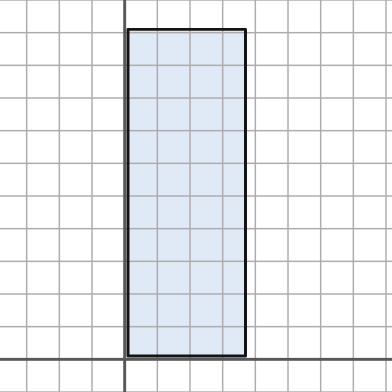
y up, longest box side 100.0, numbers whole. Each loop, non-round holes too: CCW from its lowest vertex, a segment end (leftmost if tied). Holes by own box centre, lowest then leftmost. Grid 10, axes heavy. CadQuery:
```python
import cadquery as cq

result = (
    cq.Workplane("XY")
    .moveTo(1.0, 1.0)
    .lineTo(37.0, 1.0)
    .lineTo(37.0, 101.0)
    .lineTo(1.0, 101.0)
    .close()
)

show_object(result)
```